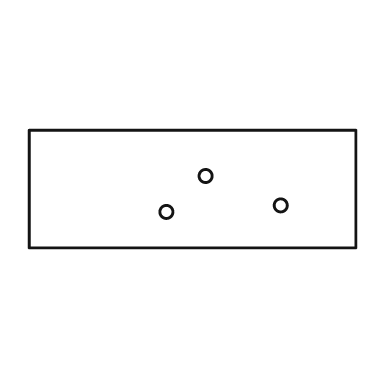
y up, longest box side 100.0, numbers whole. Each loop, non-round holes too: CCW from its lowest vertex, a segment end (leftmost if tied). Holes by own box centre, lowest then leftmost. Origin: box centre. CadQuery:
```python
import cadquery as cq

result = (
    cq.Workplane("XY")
    .moveTo(-50.0, -18.0)
    .lineTo(50.0, -18.0)
    .lineTo(50.0, 18.0)
    .lineTo(-50.0, 18.0)
    .close()
    .moveTo(-8.0, -7.0)
    .circle(2.0)
    .moveTo(27.0, -5.0)
    .circle(2.0)
    .moveTo(4.0, 4.0)
    .circle(2.0)
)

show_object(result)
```